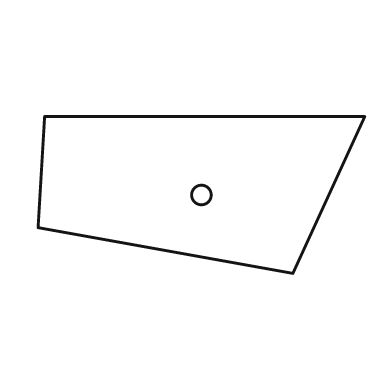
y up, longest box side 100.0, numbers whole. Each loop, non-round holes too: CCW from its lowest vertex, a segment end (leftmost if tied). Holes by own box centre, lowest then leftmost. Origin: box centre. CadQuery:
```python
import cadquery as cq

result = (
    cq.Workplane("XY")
    .moveTo(28.0, -24.0)
    .lineTo(50.0, 24.0)
    .lineTo(-48.0, 24.0)
    .lineTo(-50.0, -10.0)
    .close()
    .moveTo(0.0, 0.0)
    .circle(3.0)
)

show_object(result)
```